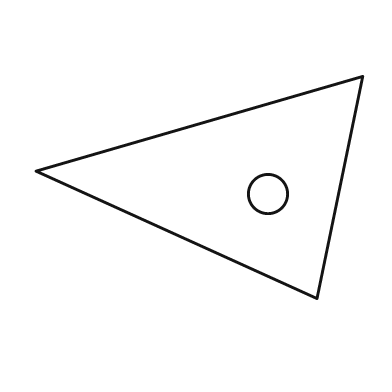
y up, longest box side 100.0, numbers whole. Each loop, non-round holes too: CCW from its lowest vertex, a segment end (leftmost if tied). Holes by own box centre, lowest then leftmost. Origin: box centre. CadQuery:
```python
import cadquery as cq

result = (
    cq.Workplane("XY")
    .moveTo(36.0, -34.0)
    .lineTo(50.0, 34.0)
    .lineTo(-50.0, 5.0)
    .close()
    .moveTo(21.0, -2.0)
    .circle(6.0)
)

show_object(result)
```